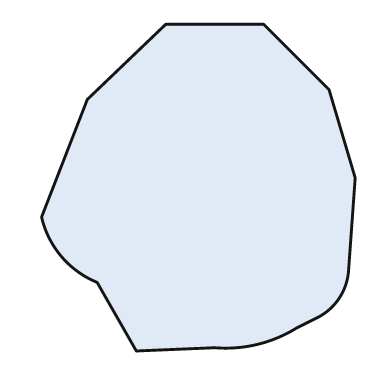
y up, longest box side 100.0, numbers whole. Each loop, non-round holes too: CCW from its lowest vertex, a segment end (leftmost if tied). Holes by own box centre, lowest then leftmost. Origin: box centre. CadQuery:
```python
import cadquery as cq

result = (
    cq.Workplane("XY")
    .moveTo(-19.0, -50.0)
    .lineTo(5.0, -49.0)
    .threePointArc((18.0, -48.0), (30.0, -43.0))
    .lineTo(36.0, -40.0)
    .threePointArc((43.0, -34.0), (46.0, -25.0))
    .lineTo(48.0, 3.0)
    .lineTo(40.0, 30.0)
    .lineTo(20.0, 50.0)
    .lineTo(-10.0, 50.0)
    .lineTo(-34.0, 27.0)
    .lineTo(-48.0, -9.0)
    .threePointArc((-42.0, -21.0), (-31.0, -29.0))
    .close()
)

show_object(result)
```